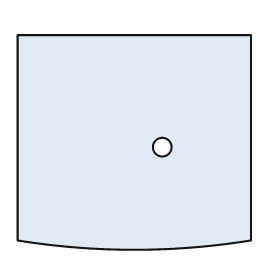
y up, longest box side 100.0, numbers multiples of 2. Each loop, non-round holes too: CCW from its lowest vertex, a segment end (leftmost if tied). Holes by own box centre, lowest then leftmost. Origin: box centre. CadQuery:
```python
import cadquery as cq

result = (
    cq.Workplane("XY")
    .moveTo(-50.0, -42.0)
    .threePointArc((0.0, -46.0), (50.0, -42.0))
    .lineTo(50.0, 46.0)
    .lineTo(-50.0, 46.0)
    .close()
    .moveTo(12.0, -2.0)
    .circle(4.0)
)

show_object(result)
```